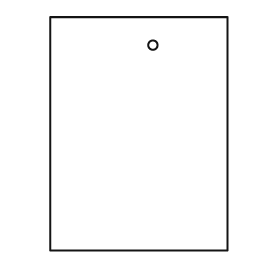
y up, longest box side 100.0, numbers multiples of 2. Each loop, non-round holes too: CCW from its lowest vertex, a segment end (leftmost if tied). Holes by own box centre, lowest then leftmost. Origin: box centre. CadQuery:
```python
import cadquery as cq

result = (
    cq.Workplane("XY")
    .moveTo(-38.0, -50.0)
    .lineTo(38.0, -50.0)
    .lineTo(38.0, 50.0)
    .lineTo(-38.0, 50.0)
    .close()
    .moveTo(6.0, 38.0)
    .circle(2.0)
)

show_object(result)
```